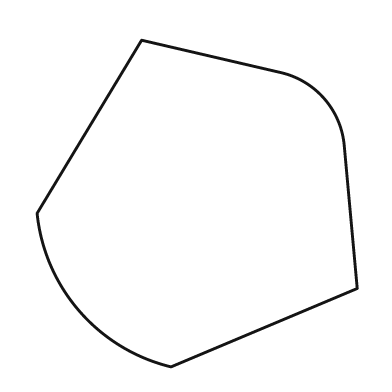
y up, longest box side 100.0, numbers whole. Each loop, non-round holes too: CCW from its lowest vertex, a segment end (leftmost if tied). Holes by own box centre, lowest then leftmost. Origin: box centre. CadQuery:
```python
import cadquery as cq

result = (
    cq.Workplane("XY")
    .moveTo(-8.0, -50.0)
    .lineTo(49.0, -26.0)
    .lineTo(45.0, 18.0)
    .threePointArc((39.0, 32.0), (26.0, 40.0))
    .lineTo(-17.0, 50.0)
    .lineTo(-49.0, -3.0)
    .threePointArc((-36.0, -33.0), (-8.0, -50.0))
    .close()
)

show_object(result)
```